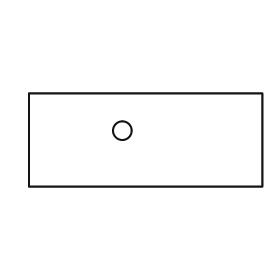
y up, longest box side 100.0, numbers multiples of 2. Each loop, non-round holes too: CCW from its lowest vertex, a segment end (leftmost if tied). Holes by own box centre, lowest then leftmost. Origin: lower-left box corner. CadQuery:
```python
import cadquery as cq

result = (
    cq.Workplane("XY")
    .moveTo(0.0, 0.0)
    .lineTo(100.0, 0.0)
    .lineTo(100.0, 40.0)
    .lineTo(0.0, 40.0)
    .close()
    .moveTo(40.0, 24.0)
    .circle(4.0)
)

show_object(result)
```